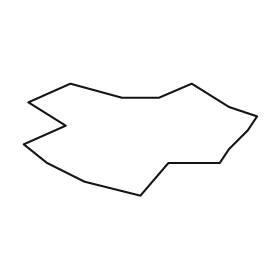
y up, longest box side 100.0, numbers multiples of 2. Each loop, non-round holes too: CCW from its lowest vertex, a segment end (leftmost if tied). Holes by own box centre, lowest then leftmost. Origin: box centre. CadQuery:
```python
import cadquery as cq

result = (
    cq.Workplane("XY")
    .moveTo(0.0, -24.0)
    .lineTo(12.0, -10.0)
    .lineTo(34.0, -10.0)
    .lineTo(38.0, -4.0)
    .lineTo(46.0, 4.0)
    .lineTo(50.0, 10.0)
    .lineTo(38.0, 14.0)
    .lineTo(22.0, 24.0)
    .lineTo(8.0, 18.0)
    .lineTo(-8.0, 18.0)
    .lineTo(-30.0, 24.0)
    .lineTo(-48.0, 16.0)
    .lineTo(-32.0, 6.0)
    .lineTo(-50.0, -2.0)
    .lineTo(-40.0, -10.0)
    .lineTo(-24.0, -18.0)
    .close()
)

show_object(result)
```